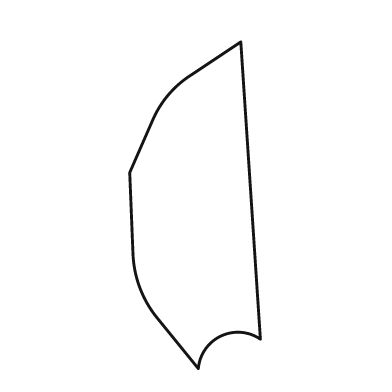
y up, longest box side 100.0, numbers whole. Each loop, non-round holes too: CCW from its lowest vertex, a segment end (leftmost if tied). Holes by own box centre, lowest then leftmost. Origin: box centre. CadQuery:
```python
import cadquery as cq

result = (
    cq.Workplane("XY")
    .moveTo(1.0, -50.0)
    .threePointArc((8.0, -40.0), (20.0, -41.0))
    .lineTo(14.0, 50.0)
    .lineTo(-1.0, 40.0)
    .threePointArc((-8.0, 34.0), (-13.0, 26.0))
    .lineTo(-20.0, 10.0)
    .lineTo(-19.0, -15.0)
    .threePointArc((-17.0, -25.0), (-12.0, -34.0))
    .close()
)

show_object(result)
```